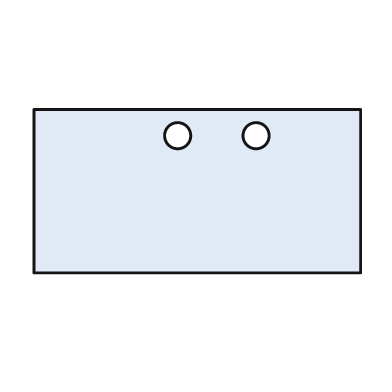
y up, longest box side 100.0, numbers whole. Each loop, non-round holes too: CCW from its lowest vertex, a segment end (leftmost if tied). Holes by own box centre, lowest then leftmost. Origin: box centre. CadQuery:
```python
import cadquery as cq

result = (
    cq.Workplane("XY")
    .moveTo(-50.0, -25.0)
    .lineTo(50.0, -25.0)
    .lineTo(50.0, 25.0)
    .lineTo(-50.0, 25.0)
    .close()
    .moveTo(-6.0, 17.0)
    .circle(4.0)
    .moveTo(18.0, 17.0)
    .circle(4.0)
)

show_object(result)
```